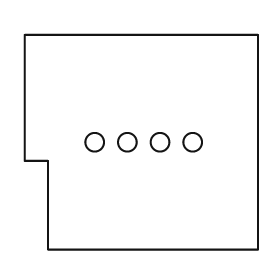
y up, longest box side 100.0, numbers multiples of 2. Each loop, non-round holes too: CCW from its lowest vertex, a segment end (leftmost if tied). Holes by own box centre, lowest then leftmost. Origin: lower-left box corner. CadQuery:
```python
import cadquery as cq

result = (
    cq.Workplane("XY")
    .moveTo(10.0, 0.0)
    .lineTo(100.0, 0.0)
    .lineTo(100.0, 92.0)
    .lineTo(0.0, 92.0)
    .lineTo(0.0, 38.0)
    .lineTo(10.0, 38.0)
    .close()
    .moveTo(30.0, 46.0)
    .circle(4.0)
    .moveTo(44.0, 46.0)
    .circle(4.0)
    .moveTo(58.0, 46.0)
    .circle(4.0)
    .moveTo(72.0, 46.0)
    .circle(4.0)
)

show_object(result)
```